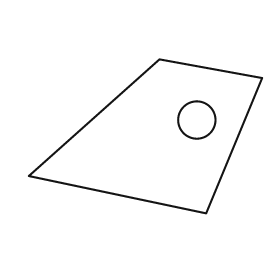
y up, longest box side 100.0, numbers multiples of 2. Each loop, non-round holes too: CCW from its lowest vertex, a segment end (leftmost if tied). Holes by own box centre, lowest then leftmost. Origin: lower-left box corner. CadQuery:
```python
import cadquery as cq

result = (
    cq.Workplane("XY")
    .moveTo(76.0, 0.0)
    .lineTo(100.0, 58.0)
    .lineTo(56.0, 66.0)
    .lineTo(0.0, 16.0)
    .close()
    .moveTo(72.0, 40.0)
    .circle(8.0)
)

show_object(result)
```